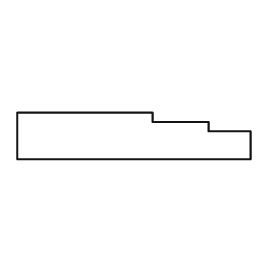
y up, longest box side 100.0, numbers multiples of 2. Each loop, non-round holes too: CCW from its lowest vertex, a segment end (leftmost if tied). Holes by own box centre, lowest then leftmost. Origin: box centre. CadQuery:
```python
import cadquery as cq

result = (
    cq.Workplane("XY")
    .moveTo(-50.0, -10.0)
    .lineTo(50.0, -10.0)
    .lineTo(50.0, 2.0)
    .lineTo(32.0, 2.0)
    .lineTo(32.0, 6.0)
    .lineTo(8.0, 6.0)
    .lineTo(8.0, 10.0)
    .lineTo(-50.0, 10.0)
    .close()
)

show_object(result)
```